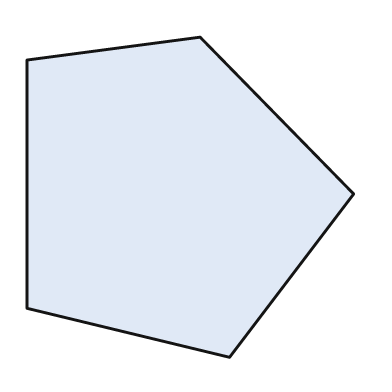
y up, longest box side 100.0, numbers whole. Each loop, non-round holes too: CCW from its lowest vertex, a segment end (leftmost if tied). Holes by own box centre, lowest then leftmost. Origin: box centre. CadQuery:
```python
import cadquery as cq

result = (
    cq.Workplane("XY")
    .moveTo(12.0, -49.0)
    .lineTo(50.0, 1.0)
    .lineTo(3.0, 49.0)
    .lineTo(-50.0, 42.0)
    .lineTo(-50.0, -34.0)
    .close()
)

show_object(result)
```